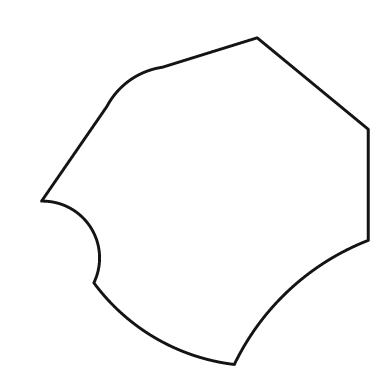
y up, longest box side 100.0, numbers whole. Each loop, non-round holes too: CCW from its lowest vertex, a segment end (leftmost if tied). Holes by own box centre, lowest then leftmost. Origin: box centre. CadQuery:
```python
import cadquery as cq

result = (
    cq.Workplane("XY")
    .moveTo(9.0, -50.0)
    .threePointArc((26.0, -27.0), (50.0, -12.0))
    .lineTo(50.0, 22.0)
    .lineTo(16.0, 50.0)
    .lineTo(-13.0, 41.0)
    .threePointArc((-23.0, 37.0), (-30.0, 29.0))
    .lineTo(-50.0, 0.0)
    .threePointArc((-35.0, -8.0), (-34.0, -25.0))
    .threePointArc((-15.0, -42.0), (9.0, -50.0))
    .close()
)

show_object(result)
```